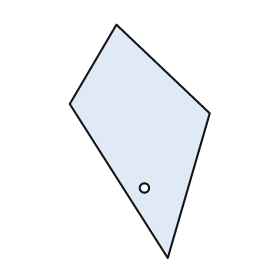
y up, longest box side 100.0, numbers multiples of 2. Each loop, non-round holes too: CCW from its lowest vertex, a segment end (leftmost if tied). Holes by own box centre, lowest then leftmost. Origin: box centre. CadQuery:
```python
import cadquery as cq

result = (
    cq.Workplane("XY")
    .moveTo(12.0, -50.0)
    .lineTo(30.0, 12.0)
    .lineTo(-10.0, 50.0)
    .lineTo(-30.0, 16.0)
    .close()
    .moveTo(2.0, -20.0)
    .circle(2.0)
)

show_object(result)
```